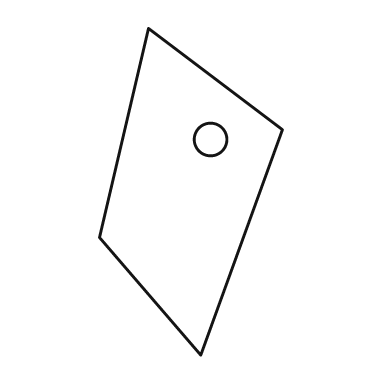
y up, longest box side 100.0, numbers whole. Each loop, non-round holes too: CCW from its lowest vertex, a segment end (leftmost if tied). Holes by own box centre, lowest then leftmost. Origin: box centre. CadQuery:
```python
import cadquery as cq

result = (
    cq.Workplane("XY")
    .moveTo(3.0, -50.0)
    .lineTo(28.0, 19.0)
    .lineTo(-13.0, 50.0)
    .lineTo(-28.0, -14.0)
    .close()
    .moveTo(6.0, 16.0)
    .circle(5.0)
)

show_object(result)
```